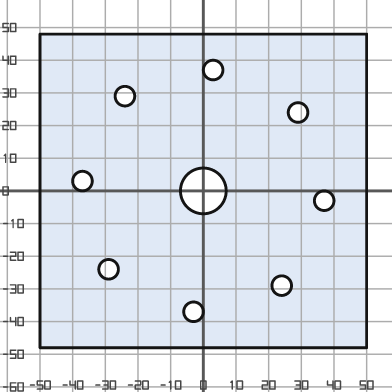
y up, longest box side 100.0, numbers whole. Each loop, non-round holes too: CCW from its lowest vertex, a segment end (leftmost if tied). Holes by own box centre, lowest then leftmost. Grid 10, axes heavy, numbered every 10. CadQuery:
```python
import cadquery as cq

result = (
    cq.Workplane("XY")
    .moveTo(-50.0, -48.0)
    .lineTo(50.0, -48.0)
    .lineTo(50.0, 48.0)
    .lineTo(-50.0, 48.0)
    .close()
    .moveTo(-3.0, -37.0)
    .circle(3.0)
    .moveTo(24.0, -29.0)
    .circle(3.0)
    .moveTo(-29.0, -24.0)
    .circle(3.0)
    .moveTo(37.0, -3.0)
    .circle(3.0)
    .moveTo(0.0, 0.0)
    .circle(7.0)
    .moveTo(-37.0, 3.0)
    .circle(3.0)
    .moveTo(29.0, 24.0)
    .circle(3.0)
    .moveTo(-24.0, 29.0)
    .circle(3.0)
    .moveTo(3.0, 37.0)
    .circle(3.0)
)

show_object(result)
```